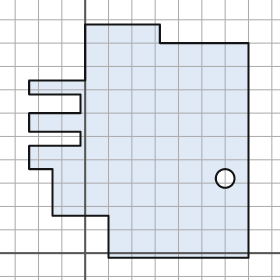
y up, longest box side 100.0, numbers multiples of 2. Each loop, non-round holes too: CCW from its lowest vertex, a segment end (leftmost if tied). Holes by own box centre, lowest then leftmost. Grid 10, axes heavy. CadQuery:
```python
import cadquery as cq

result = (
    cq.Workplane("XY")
    .moveTo(10.0, -2.0)
    .lineTo(70.0, -2.0)
    .lineTo(70.0, 90.0)
    .lineTo(32.0, 90.0)
    .lineTo(32.0, 98.0)
    .lineTo(0.0, 98.0)
    .lineTo(0.0, 74.0)
    .lineTo(-24.0, 74.0)
    .lineTo(-24.0, 68.0)
    .lineTo(-2.0, 68.0)
    .lineTo(-2.0, 60.0)
    .lineTo(-24.0, 60.0)
    .lineTo(-24.0, 52.0)
    .lineTo(-2.0, 52.0)
    .lineTo(-2.0, 46.0)
    .lineTo(-24.0, 46.0)
    .lineTo(-24.0, 36.0)
    .lineTo(-14.0, 36.0)
    .lineTo(-14.0, 16.0)
    .lineTo(10.0, 16.0)
    .close()
    .moveTo(60.0, 32.0)
    .circle(4.0)
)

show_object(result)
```